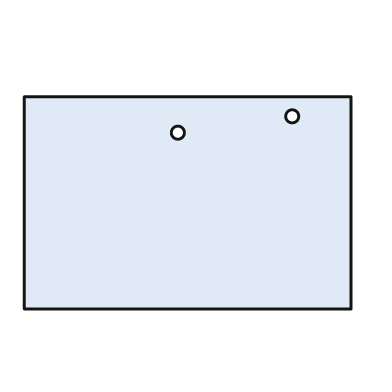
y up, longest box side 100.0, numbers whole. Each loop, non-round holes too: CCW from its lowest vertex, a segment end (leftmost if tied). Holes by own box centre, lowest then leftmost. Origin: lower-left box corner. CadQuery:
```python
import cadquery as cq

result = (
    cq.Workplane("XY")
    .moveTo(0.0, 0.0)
    .lineTo(100.0, 0.0)
    .lineTo(100.0, 65.0)
    .lineTo(0.0, 65.0)
    .close()
    .moveTo(47.0, 54.0)
    .circle(2.0)
    .moveTo(82.0, 59.0)
    .circle(2.0)
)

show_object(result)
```